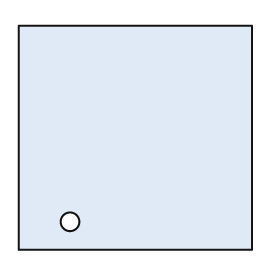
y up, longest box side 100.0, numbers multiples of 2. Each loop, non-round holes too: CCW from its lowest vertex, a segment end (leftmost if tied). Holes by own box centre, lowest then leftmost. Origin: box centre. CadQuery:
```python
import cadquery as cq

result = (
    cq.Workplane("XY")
    .moveTo(-50.0, -48.0)
    .lineTo(50.0, -48.0)
    .lineTo(50.0, 48.0)
    .lineTo(-50.0, 48.0)
    .close()
    .moveTo(-28.0, -36.0)
    .circle(4.0)
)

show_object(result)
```